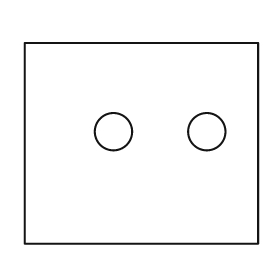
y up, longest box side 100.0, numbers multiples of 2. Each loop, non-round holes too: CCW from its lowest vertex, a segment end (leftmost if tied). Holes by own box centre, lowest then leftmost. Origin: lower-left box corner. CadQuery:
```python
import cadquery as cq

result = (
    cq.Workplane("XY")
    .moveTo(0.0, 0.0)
    .lineTo(100.0, 0.0)
    .lineTo(100.0, 86.0)
    .lineTo(0.0, 86.0)
    .close()
    .moveTo(38.0, 48.0)
    .circle(8.0)
    .moveTo(78.0, 48.0)
    .circle(8.0)
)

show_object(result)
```